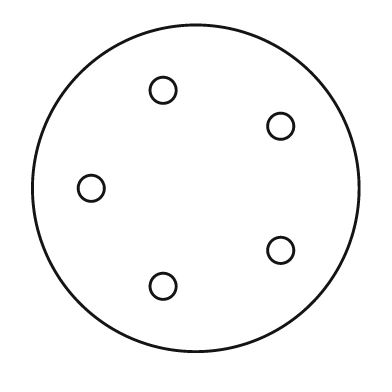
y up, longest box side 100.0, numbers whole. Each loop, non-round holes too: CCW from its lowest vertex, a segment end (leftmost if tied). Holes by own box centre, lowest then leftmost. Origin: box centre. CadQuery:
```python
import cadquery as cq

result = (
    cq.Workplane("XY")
    .moveTo(0.0, 0.0)
    .circle(50.0)
    .moveTo(-10.0, -30.0)
    .circle(4.0)
    .moveTo(26.0, -19.0)
    .circle(4.0)
    .moveTo(-32.0, 0.0)
    .circle(4.0)
    .moveTo(26.0, 19.0)
    .circle(4.0)
    .moveTo(-10.0, 30.0)
    .circle(4.0)
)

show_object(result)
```